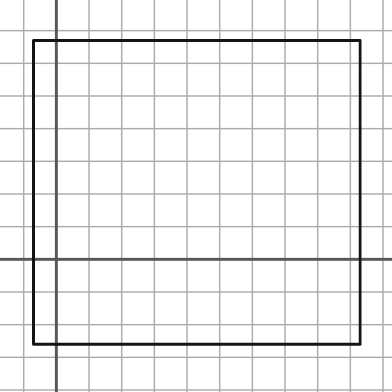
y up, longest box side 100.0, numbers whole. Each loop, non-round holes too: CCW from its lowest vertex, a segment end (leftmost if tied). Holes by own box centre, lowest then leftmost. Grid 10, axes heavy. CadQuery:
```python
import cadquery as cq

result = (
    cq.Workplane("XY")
    .moveTo(-7.0, -26.0)
    .lineTo(93.0, -26.0)
    .lineTo(93.0, 67.0)
    .lineTo(-7.0, 67.0)
    .close()
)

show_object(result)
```